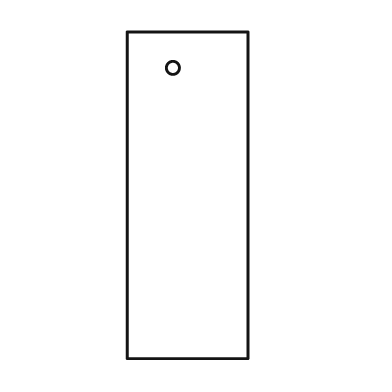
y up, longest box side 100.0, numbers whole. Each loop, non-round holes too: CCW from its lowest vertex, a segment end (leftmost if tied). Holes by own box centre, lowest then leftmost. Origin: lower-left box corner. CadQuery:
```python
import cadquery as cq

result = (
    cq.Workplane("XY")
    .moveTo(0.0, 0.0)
    .lineTo(37.0, 0.0)
    .lineTo(37.0, 100.0)
    .lineTo(0.0, 100.0)
    .close()
    .moveTo(14.0, 89.0)
    .circle(2.0)
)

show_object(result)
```